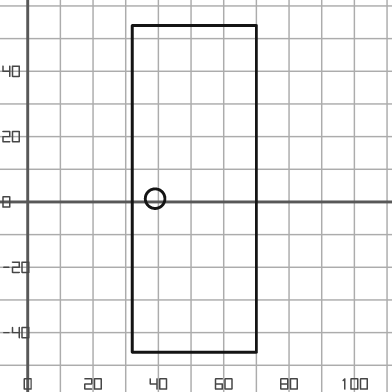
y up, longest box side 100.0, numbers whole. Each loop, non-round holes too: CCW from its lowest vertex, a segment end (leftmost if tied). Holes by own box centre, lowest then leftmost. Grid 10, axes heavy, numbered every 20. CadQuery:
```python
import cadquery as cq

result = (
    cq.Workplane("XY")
    .moveTo(32.0, -46.0)
    .lineTo(70.0, -46.0)
    .lineTo(70.0, 54.0)
    .lineTo(32.0, 54.0)
    .close()
    .moveTo(39.0, 1.0)
    .circle(3.0)
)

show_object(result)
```